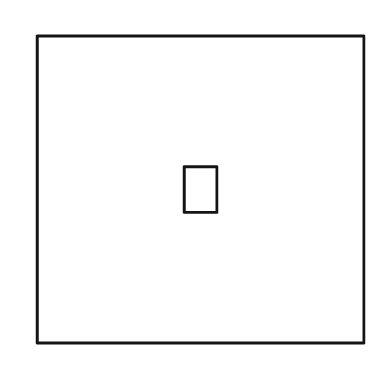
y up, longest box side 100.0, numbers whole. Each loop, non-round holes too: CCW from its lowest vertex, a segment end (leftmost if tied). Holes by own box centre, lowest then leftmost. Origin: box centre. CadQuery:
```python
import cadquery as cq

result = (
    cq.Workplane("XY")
    .moveTo(-50.0, -47.0)
    .lineTo(50.0, -47.0)
    .lineTo(50.0, 47.0)
    .lineTo(-50.0, 47.0)
    .close()
    .moveTo(-5.0, -7.0)
    .lineTo(5.0, -7.0)
    .lineTo(5.0, 7.0)
    .lineTo(-5.0, 7.0)
    .close()
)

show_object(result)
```